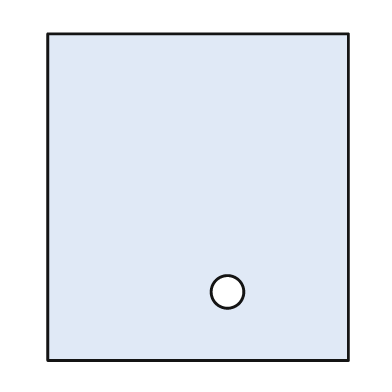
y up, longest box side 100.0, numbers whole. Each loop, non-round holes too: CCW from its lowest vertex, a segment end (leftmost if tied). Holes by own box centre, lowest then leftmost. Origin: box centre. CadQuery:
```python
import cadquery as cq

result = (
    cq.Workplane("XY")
    .moveTo(-46.0, -50.0)
    .lineTo(46.0, -50.0)
    .lineTo(46.0, 50.0)
    .lineTo(-46.0, 50.0)
    .close()
    .moveTo(9.0, -29.0)
    .circle(5.0)
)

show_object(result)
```